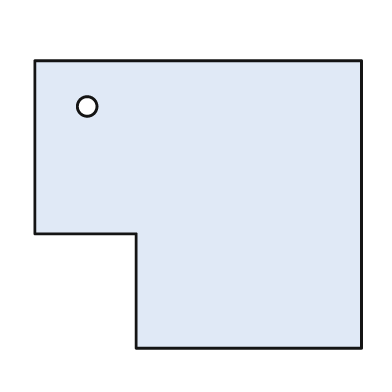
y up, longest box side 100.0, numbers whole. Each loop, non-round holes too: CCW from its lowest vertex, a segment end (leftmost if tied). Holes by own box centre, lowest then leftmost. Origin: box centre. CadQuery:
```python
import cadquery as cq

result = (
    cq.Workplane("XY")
    .moveTo(-19.0, -44.0)
    .lineTo(50.0, -44.0)
    .lineTo(50.0, 44.0)
    .lineTo(-50.0, 44.0)
    .lineTo(-50.0, -9.0)
    .lineTo(-19.0, -9.0)
    .close()
    .moveTo(-34.0, 30.0)
    .circle(3.0)
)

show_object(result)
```